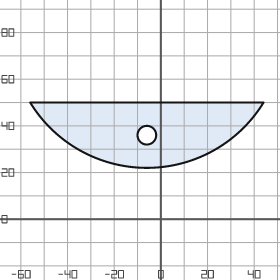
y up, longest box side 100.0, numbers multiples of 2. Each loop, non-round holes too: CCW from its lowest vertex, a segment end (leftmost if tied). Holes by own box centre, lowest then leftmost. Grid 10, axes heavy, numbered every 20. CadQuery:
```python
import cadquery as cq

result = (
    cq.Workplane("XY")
    .moveTo(-56.0, 50.0)
    .threePointArc((-6.0, 22.0), (44.0, 50.0))
    .close()
    .moveTo(-6.0, 36.0)
    .circle(4.0)
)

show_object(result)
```